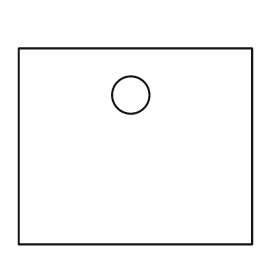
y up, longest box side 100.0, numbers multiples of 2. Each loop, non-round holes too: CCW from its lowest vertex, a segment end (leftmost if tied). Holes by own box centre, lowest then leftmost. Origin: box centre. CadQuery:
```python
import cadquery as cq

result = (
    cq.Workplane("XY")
    .moveTo(-50.0, -42.0)
    .lineTo(50.0, -42.0)
    .lineTo(50.0, 42.0)
    .lineTo(-50.0, 42.0)
    .close()
    .moveTo(-2.0, 22.0)
    .circle(8.0)
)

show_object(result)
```